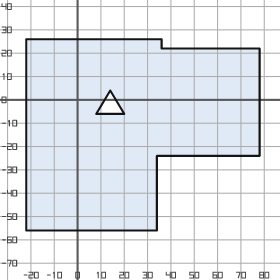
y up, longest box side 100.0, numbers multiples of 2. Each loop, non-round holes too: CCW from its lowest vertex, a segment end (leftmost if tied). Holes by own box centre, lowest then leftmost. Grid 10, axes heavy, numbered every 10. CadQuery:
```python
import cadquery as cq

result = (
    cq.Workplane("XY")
    .moveTo(-22.0, -56.0)
    .lineTo(34.0, -56.0)
    .lineTo(34.0, -24.0)
    .lineTo(78.0, -24.0)
    .lineTo(78.0, 22.0)
    .lineTo(36.0, 22.0)
    .lineTo(36.0, 26.0)
    .lineTo(-22.0, 26.0)
    .close()
    .moveTo(8.0, -6.0)
    .lineTo(20.0, -6.0)
    .lineTo(14.0, 4.0)
    .close()
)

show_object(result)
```